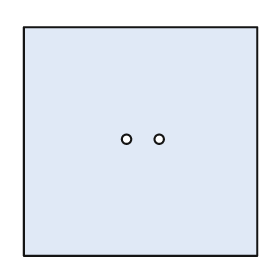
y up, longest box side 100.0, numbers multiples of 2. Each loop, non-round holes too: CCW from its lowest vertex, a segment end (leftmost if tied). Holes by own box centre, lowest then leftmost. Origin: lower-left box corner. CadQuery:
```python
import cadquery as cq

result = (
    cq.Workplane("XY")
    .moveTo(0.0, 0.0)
    .lineTo(100.0, 0.0)
    .lineTo(100.0, 98.0)
    .lineTo(0.0, 98.0)
    .close()
    .moveTo(44.0, 50.0)
    .circle(2.0)
    .moveTo(58.0, 50.0)
    .circle(2.0)
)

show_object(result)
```